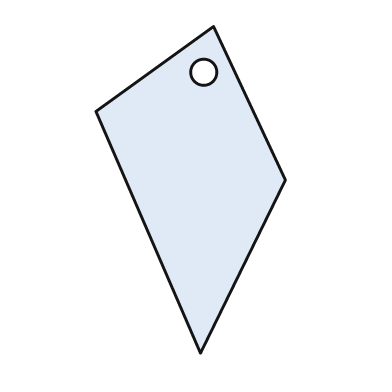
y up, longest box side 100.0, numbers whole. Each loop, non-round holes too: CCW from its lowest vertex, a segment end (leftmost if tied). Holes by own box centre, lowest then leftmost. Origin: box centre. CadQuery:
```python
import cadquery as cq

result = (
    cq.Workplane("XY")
    .moveTo(3.0, -50.0)
    .lineTo(29.0, 3.0)
    .lineTo(7.0, 50.0)
    .lineTo(-29.0, 24.0)
    .close()
    .moveTo(4.0, 36.0)
    .circle(4.0)
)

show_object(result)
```